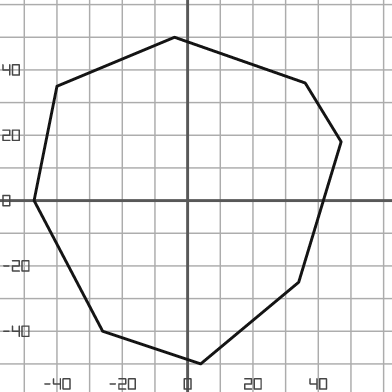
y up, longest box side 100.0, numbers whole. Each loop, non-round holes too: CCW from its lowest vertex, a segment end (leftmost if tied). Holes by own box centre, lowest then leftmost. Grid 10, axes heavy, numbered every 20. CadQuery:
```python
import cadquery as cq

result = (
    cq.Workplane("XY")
    .moveTo(4.0, -50.0)
    .lineTo(34.0, -25.0)
    .lineTo(47.0, 18.0)
    .lineTo(36.0, 36.0)
    .lineTo(-4.0, 50.0)
    .lineTo(-40.0, 35.0)
    .lineTo(-47.0, 0.0)
    .lineTo(-26.0, -40.0)
    .close()
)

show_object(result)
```